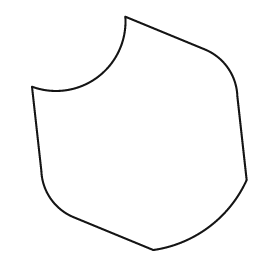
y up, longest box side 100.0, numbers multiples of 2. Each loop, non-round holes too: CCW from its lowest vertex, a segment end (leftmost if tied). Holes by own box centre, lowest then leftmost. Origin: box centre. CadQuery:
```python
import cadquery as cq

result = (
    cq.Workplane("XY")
    .moveTo(6.0, -50.0)
    .threePointArc((30.0, -40.0), (46.0, -20.0))
    .lineTo(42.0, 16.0)
    .threePointArc((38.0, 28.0), (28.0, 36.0))
    .lineTo(-6.0, 50.0)
    .threePointArc((-18.0, 24.0), (-46.0, 20.0))
    .lineTo(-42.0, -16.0)
    .threePointArc((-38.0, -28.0), (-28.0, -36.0))
    .close()
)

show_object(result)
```